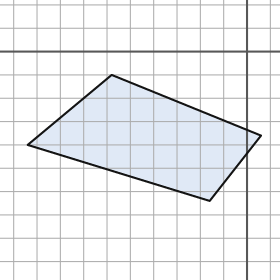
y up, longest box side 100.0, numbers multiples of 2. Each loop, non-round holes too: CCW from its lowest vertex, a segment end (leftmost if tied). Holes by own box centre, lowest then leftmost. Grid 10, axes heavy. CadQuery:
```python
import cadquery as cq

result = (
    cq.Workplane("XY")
    .moveTo(-16.0, -64.0)
    .lineTo(6.0, -36.0)
    .lineTo(-58.0, -10.0)
    .lineTo(-94.0, -40.0)
    .close()
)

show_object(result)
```